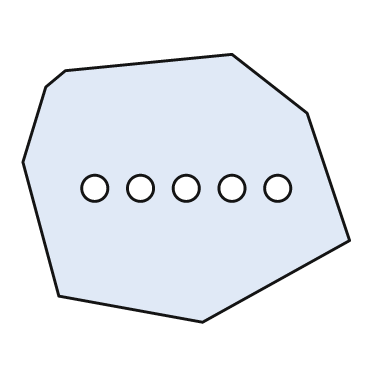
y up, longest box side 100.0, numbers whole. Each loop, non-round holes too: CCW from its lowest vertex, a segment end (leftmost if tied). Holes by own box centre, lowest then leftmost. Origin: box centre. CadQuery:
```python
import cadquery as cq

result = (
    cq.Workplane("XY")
    .moveTo(5.0, -41.0)
    .lineTo(50.0, -16.0)
    .lineTo(37.0, 23.0)
    .lineTo(14.0, 41.0)
    .lineTo(-37.0, 36.0)
    .lineTo(-43.0, 31.0)
    .lineTo(-50.0, 8.0)
    .lineTo(-39.0, -33.0)
    .close()
    .moveTo(-28.0, 0.0)
    .circle(4.0)
    .moveTo(-14.0, 0.0)
    .circle(4.0)
    .moveTo(0.0, 0.0)
    .circle(4.0)
    .moveTo(14.0, 0.0)
    .circle(4.0)
    .moveTo(28.0, 0.0)
    .circle(4.0)
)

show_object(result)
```